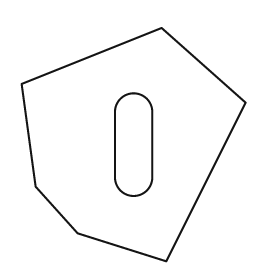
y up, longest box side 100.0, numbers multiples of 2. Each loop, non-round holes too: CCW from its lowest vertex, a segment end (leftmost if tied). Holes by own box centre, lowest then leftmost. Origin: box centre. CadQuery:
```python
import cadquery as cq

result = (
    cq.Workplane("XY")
    .moveTo(14.0, -50.0)
    .lineTo(48.0, 18.0)
    .lineTo(12.0, 50.0)
    .lineTo(-48.0, 26.0)
    .lineTo(-42.0, -18.0)
    .lineTo(-24.0, -38.0)
    .close()
    .moveTo(-8.0, -14.0)
    .threePointArc((0.0, -22.0), (8.0, -14.0))
    .lineTo(8.0, 14.0)
    .threePointArc((0.0, 22.0), (-8.0, 14.0))
    .close()
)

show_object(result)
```